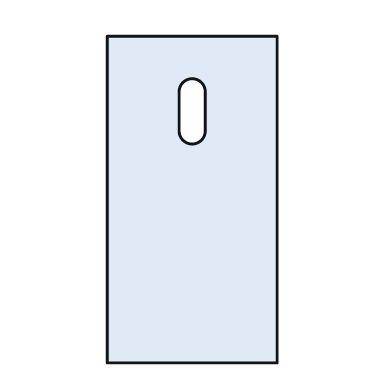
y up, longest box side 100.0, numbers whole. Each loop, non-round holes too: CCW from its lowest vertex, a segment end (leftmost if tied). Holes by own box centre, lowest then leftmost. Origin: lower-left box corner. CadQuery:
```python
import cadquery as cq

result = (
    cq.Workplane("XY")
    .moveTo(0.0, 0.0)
    .lineTo(52.0, 0.0)
    .lineTo(52.0, 100.0)
    .lineTo(0.0, 100.0)
    .close()
    .moveTo(22.0, 71.0)
    .threePointArc((26.0, 67.0), (30.0, 71.0))
    .lineTo(30.0, 83.0)
    .threePointArc((26.0, 87.0), (22.0, 83.0))
    .close()
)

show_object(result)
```